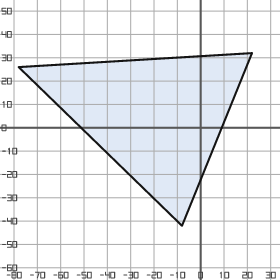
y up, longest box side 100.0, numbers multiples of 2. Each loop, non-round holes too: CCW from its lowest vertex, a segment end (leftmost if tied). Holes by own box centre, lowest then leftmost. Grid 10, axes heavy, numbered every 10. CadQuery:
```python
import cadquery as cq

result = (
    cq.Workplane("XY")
    .moveTo(-8.0, -42.0)
    .lineTo(22.0, 32.0)
    .lineTo(-78.0, 26.0)
    .close()
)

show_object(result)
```